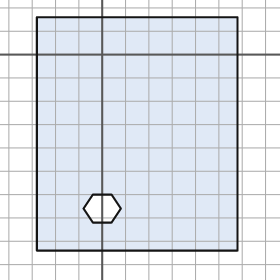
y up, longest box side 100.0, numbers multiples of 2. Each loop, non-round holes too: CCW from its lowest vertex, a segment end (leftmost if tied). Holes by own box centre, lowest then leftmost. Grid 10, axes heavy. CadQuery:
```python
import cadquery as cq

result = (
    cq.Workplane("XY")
    .moveTo(-28.0, -84.0)
    .lineTo(58.0, -84.0)
    .lineTo(58.0, 16.0)
    .lineTo(-28.0, 16.0)
    .close()
    .moveTo(-4.0, -72.0)
    .lineTo(4.0, -72.0)
    .lineTo(8.0, -66.0)
    .lineTo(4.0, -60.0)
    .lineTo(-4.0, -60.0)
    .lineTo(-8.0, -66.0)
    .close()
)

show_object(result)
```